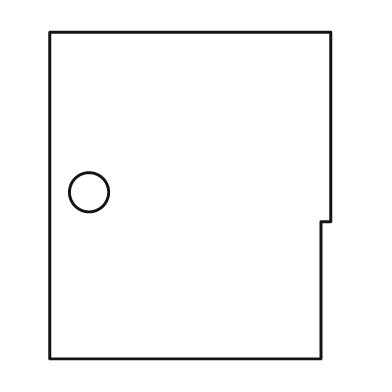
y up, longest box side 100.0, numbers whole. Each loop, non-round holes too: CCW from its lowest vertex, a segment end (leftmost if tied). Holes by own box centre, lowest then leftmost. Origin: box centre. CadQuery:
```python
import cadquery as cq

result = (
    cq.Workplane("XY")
    .moveTo(-43.0, -50.0)
    .lineTo(40.0, -50.0)
    .lineTo(40.0, -8.0)
    .lineTo(43.0, -8.0)
    .lineTo(43.0, 50.0)
    .lineTo(-43.0, 50.0)
    .close()
    .moveTo(-31.0, 1.0)
    .circle(6.0)
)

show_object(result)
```